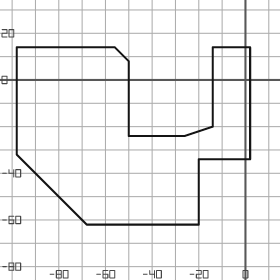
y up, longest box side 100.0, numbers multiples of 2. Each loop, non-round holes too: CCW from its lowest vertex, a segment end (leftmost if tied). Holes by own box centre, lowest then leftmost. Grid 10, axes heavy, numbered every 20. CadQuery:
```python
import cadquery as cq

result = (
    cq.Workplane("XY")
    .moveTo(-68.0, -62.0)
    .lineTo(-20.0, -62.0)
    .lineTo(-20.0, -34.0)
    .lineTo(2.0, -34.0)
    .lineTo(2.0, 14.0)
    .lineTo(-14.0, 14.0)
    .lineTo(-14.0, -20.0)
    .lineTo(-26.0, -24.0)
    .lineTo(-50.0, -24.0)
    .lineTo(-50.0, 8.0)
    .lineTo(-56.0, 14.0)
    .lineTo(-98.0, 14.0)
    .lineTo(-98.0, -32.0)
    .close()
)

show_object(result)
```